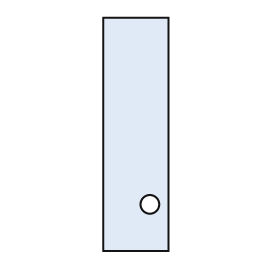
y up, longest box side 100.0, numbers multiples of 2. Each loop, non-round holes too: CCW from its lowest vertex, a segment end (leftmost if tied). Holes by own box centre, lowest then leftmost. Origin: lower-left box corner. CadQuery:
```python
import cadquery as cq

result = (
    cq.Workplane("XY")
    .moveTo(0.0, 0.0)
    .lineTo(28.0, 0.0)
    .lineTo(28.0, 100.0)
    .lineTo(0.0, 100.0)
    .close()
    .moveTo(20.0, 20.0)
    .circle(4.0)
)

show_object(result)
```